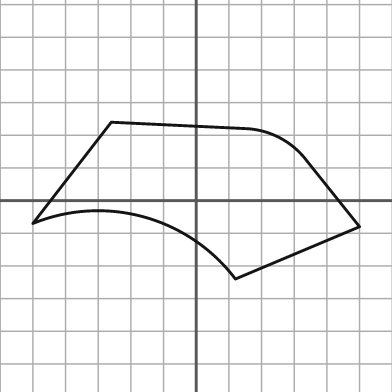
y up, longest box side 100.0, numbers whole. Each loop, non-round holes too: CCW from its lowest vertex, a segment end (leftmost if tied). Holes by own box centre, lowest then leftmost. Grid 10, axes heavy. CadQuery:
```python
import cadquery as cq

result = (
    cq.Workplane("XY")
    .moveTo(12.0, -24.0)
    .lineTo(50.0, -8.0)
    .lineTo(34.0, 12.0)
    .threePointArc((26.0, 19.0), (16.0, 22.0))
    .lineTo(-26.0, 24.0)
    .lineTo(-50.0, -7.0)
    .threePointArc((-16.0, -5.0), (12.0, -24.0))
    .close()
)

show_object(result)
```